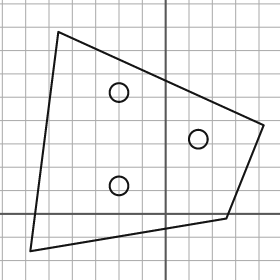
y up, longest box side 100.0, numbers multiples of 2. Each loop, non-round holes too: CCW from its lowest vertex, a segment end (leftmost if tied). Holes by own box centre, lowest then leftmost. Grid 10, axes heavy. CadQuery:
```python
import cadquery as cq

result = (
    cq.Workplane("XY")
    .moveTo(-58.0, -16.0)
    .lineTo(26.0, -2.0)
    .lineTo(42.0, 38.0)
    .lineTo(-46.0, 78.0)
    .close()
    .moveTo(-20.0, 12.0)
    .circle(4.0)
    .moveTo(14.0, 32.0)
    .circle(4.0)
    .moveTo(-20.0, 52.0)
    .circle(4.0)
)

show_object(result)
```